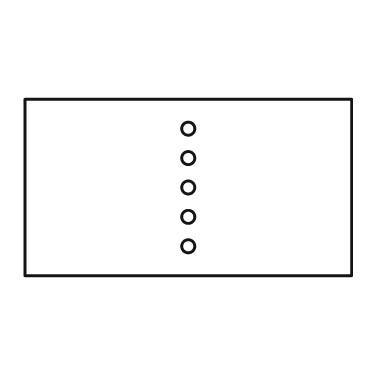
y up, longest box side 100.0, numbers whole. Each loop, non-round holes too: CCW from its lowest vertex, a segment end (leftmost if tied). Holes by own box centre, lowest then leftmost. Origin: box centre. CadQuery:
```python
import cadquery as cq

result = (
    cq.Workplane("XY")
    .moveTo(-50.0, -27.0)
    .lineTo(50.0, -27.0)
    .lineTo(50.0, 27.0)
    .lineTo(-50.0, 27.0)
    .close()
    .moveTo(0.0, -18.0)
    .circle(2.0)
    .moveTo(0.0, -9.0)
    .circle(2.0)
    .moveTo(0.0, 0.0)
    .circle(2.0)
    .moveTo(0.0, 9.0)
    .circle(2.0)
    .moveTo(0.0, 18.0)
    .circle(2.0)
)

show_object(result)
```